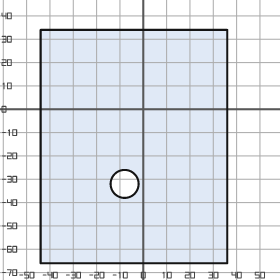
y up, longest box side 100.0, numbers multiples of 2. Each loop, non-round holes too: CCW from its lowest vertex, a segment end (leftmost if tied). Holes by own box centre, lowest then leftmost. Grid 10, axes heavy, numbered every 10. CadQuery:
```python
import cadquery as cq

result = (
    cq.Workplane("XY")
    .moveTo(-44.0, -66.0)
    .lineTo(36.0, -66.0)
    .lineTo(36.0, 34.0)
    .lineTo(-44.0, 34.0)
    .close()
    .moveTo(-8.0, -32.0)
    .circle(6.0)
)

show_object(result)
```